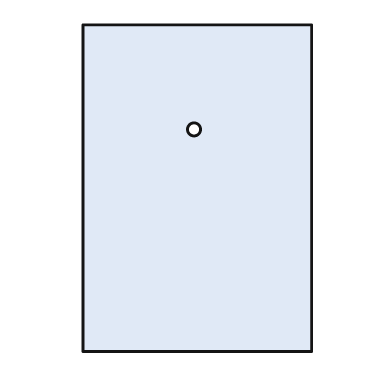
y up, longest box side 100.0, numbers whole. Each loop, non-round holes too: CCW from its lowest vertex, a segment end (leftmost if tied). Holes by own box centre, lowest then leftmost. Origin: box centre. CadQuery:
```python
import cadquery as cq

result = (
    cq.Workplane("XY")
    .moveTo(-35.0, -50.0)
    .lineTo(35.0, -50.0)
    .lineTo(35.0, 50.0)
    .lineTo(-35.0, 50.0)
    .close()
    .moveTo(-1.0, 18.0)
    .circle(2.0)
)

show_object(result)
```